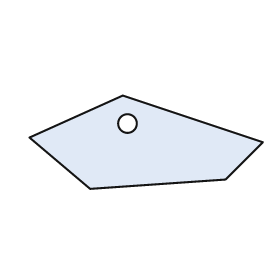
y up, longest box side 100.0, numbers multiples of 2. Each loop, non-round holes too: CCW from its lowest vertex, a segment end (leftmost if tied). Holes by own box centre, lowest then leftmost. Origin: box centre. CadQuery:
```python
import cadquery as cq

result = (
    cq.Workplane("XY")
    .moveTo(-24.0, -20.0)
    .lineTo(34.0, -16.0)
    .lineTo(50.0, 0.0)
    .lineTo(-10.0, 20.0)
    .lineTo(-50.0, 2.0)
    .close()
    .moveTo(-8.0, 8.0)
    .circle(4.0)
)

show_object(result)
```